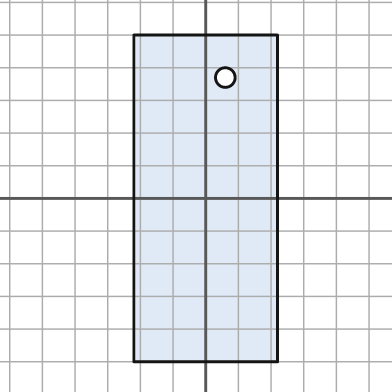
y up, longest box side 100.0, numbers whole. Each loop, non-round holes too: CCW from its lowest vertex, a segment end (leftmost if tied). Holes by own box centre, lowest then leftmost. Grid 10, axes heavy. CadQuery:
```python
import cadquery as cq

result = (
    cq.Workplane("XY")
    .moveTo(-22.0, -50.0)
    .lineTo(22.0, -50.0)
    .lineTo(22.0, 50.0)
    .lineTo(-22.0, 50.0)
    .close()
    .moveTo(6.0, 37.0)
    .circle(3.0)
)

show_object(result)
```